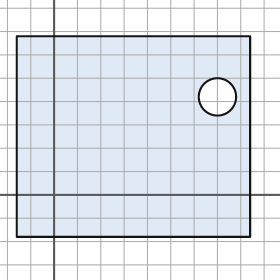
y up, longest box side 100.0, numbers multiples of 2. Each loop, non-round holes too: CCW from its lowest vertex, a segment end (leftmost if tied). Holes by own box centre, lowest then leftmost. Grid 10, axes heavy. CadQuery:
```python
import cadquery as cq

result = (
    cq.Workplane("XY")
    .moveTo(-16.0, -18.0)
    .lineTo(84.0, -18.0)
    .lineTo(84.0, 68.0)
    .lineTo(-16.0, 68.0)
    .close()
    .moveTo(70.0, 42.0)
    .circle(8.0)
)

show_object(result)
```